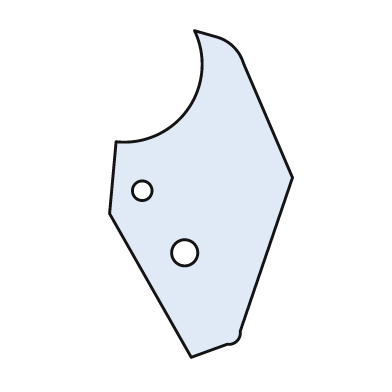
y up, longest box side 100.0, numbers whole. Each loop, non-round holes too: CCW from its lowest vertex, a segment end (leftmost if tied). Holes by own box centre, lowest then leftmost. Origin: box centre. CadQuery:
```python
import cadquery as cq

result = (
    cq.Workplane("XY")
    .moveTo(-3.0, -50.0)
    .lineTo(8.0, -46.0)
    .threePointArc((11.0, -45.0), (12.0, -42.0))
    .lineTo(28.0, 5.0)
    .lineTo(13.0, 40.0)
    .threePointArc((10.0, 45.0), (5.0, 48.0))
    .lineTo(-2.0, 50.0)
    .threePointArc((-4.0, 26.0), (-26.0, 16.0))
    .lineTo(-28.0, -6.0)
    .close()
    .moveTo(-5.0, -18.0)
    .circle(4.0)
    .moveTo(-18.0, 1.0)
    .circle(3.0)
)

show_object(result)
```